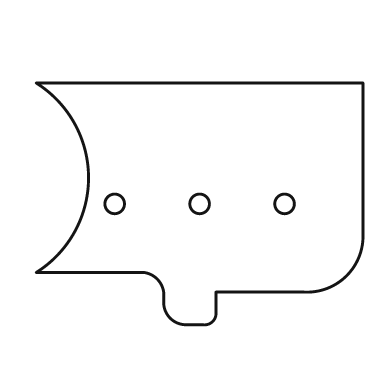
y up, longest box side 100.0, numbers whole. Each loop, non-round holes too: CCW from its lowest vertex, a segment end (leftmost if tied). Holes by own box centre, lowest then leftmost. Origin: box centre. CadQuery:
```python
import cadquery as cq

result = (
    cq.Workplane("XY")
    .moveTo(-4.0, -37.0)
    .lineTo(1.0, -37.0)
    .threePointArc((4.0, -36.0), (5.0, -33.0))
    .lineTo(5.0, -27.0)
    .lineTo(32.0, -27.0)
    .threePointArc((45.0, -22.0), (50.0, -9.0))
    .lineTo(50.0, 37.0)
    .lineTo(-50.0, 37.0)
    .threePointArc((-34.0, 8.0), (-50.0, -21.0))
    .lineTo(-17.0, -21.0)
    .threePointArc((-13.0, -23.0), (-11.0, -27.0))
    .lineTo(-11.0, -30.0)
    .threePointArc((-9.0, -35.0), (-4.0, -37.0))
    .close()
    .moveTo(-26.0, 0.0)
    .circle(3.0)
    .moveTo(0.0, 0.0)
    .circle(3.0)
    .moveTo(26.0, 0.0)
    .circle(3.0)
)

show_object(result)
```